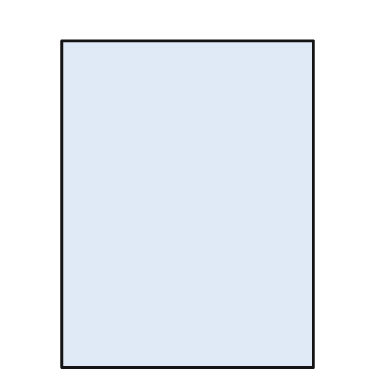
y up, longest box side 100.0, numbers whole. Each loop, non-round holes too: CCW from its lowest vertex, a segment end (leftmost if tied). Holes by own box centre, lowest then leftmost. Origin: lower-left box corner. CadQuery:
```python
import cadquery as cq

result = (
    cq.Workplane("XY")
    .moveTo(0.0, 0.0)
    .lineTo(77.0, 0.0)
    .lineTo(77.0, 100.0)
    .lineTo(0.0, 100.0)
    .close()
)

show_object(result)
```